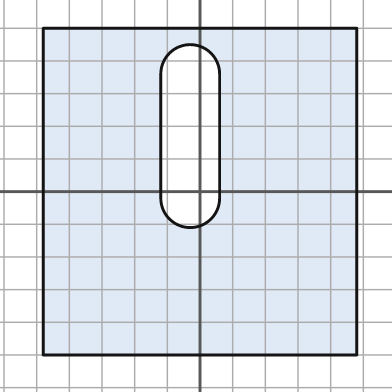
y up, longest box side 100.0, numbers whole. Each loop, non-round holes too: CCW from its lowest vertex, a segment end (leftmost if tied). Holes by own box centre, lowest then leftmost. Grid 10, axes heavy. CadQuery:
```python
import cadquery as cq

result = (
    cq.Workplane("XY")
    .moveTo(-48.0, -50.0)
    .lineTo(48.0, -50.0)
    .lineTo(48.0, 50.0)
    .lineTo(-48.0, 50.0)
    .close()
    .moveTo(-12.0, -2.0)
    .threePointArc((-3.0, -11.0), (6.0, -2.0))
    .lineTo(6.0, 36.0)
    .threePointArc((-3.0, 45.0), (-12.0, 36.0))
    .close()
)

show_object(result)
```